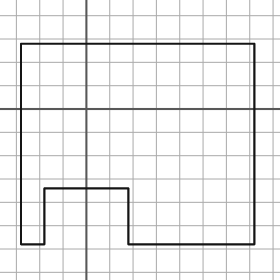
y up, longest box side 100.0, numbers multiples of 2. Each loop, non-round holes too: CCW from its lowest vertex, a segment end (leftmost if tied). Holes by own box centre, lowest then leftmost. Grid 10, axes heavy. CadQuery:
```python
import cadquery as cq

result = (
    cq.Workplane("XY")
    .moveTo(-28.0, -58.0)
    .lineTo(-18.0, -58.0)
    .lineTo(-18.0, -34.0)
    .lineTo(18.0, -34.0)
    .lineTo(18.0, -58.0)
    .lineTo(72.0, -58.0)
    .lineTo(72.0, 28.0)
    .lineTo(-28.0, 28.0)
    .close()
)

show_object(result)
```